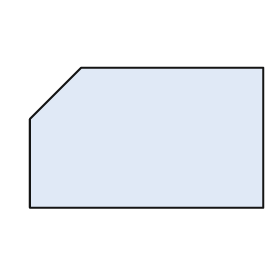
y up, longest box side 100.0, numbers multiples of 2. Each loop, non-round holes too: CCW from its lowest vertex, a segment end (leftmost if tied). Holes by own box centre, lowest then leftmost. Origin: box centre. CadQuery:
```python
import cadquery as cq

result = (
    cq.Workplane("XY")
    .moveTo(-50.0, -30.0)
    .lineTo(50.0, -30.0)
    .lineTo(50.0, 30.0)
    .lineTo(-28.0, 30.0)
    .lineTo(-50.0, 8.0)
    .close()
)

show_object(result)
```